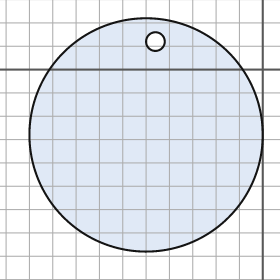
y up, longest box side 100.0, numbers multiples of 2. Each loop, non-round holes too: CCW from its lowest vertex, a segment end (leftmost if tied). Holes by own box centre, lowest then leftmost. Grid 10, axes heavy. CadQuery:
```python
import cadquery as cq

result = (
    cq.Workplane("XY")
    .moveTo(-50.0, -28.0)
    .circle(50.0)
    .moveTo(-46.0, 12.0)
    .circle(4.0)
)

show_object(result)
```